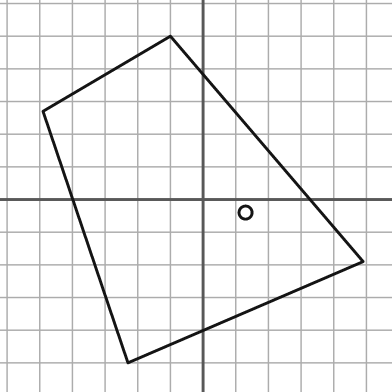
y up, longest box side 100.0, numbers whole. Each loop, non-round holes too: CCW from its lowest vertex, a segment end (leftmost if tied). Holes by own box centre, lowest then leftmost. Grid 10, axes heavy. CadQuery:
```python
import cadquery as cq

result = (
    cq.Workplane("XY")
    .moveTo(-23.0, -50.0)
    .lineTo(49.0, -19.0)
    .lineTo(-10.0, 50.0)
    .lineTo(-49.0, 27.0)
    .close()
    .moveTo(13.0, -4.0)
    .circle(2.0)
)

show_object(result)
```